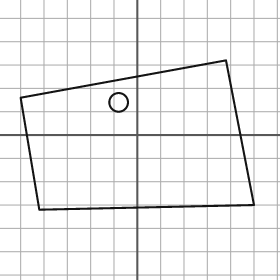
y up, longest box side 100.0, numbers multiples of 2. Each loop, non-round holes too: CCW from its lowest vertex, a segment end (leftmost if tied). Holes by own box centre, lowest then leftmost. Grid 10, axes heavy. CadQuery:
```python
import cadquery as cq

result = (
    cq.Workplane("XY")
    .moveTo(-42.0, -32.0)
    .lineTo(50.0, -30.0)
    .lineTo(38.0, 32.0)
    .lineTo(-50.0, 16.0)
    .close()
    .moveTo(-8.0, 14.0)
    .circle(4.0)
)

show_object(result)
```